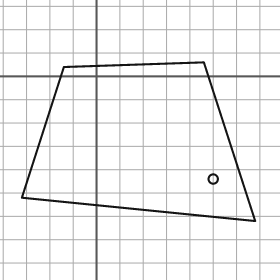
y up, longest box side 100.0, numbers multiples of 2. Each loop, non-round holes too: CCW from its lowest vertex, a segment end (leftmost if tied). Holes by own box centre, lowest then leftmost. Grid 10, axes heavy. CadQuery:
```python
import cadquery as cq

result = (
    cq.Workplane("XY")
    .moveTo(68.0, -62.0)
    .lineTo(46.0, 6.0)
    .lineTo(-14.0, 4.0)
    .lineTo(-32.0, -52.0)
    .close()
    .moveTo(50.0, -44.0)
    .circle(2.0)
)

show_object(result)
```